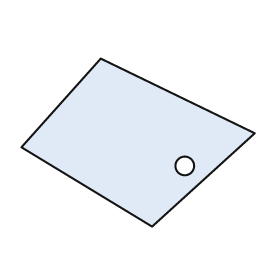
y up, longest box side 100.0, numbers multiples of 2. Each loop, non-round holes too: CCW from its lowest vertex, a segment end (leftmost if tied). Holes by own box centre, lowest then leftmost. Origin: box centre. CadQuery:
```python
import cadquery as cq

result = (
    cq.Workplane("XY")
    .moveTo(6.0, -36.0)
    .lineTo(50.0, 4.0)
    .lineTo(-16.0, 36.0)
    .lineTo(-50.0, -2.0)
    .close()
    .moveTo(20.0, -10.0)
    .circle(4.0)
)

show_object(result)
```